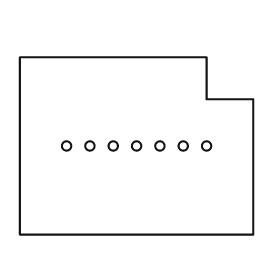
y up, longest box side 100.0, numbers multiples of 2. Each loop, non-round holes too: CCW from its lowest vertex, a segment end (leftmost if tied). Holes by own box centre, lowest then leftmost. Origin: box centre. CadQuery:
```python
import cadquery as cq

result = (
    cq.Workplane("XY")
    .moveTo(-50.0, -38.0)
    .lineTo(50.0, -38.0)
    .lineTo(50.0, 20.0)
    .lineTo(30.0, 20.0)
    .lineTo(30.0, 38.0)
    .lineTo(-50.0, 38.0)
    .close()
    .moveTo(-30.0, 0.0)
    .circle(2.0)
    .moveTo(-20.0, 0.0)
    .circle(2.0)
    .moveTo(-10.0, 0.0)
    .circle(2.0)
    .moveTo(0.0, 0.0)
    .circle(2.0)
    .moveTo(10.0, 0.0)
    .circle(2.0)
    .moveTo(20.0, 0.0)
    .circle(2.0)
    .moveTo(30.0, 0.0)
    .circle(2.0)
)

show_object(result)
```